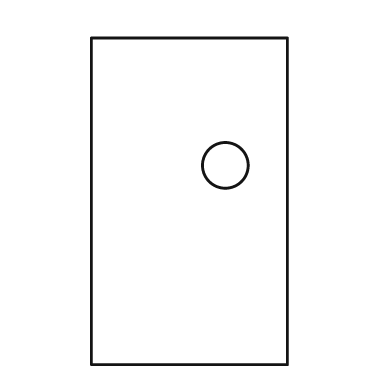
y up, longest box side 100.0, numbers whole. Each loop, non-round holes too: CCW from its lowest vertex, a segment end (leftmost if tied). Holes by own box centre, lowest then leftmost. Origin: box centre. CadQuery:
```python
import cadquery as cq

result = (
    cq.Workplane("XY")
    .moveTo(-30.0, -50.0)
    .lineTo(30.0, -50.0)
    .lineTo(30.0, 50.0)
    .lineTo(-30.0, 50.0)
    .close()
    .moveTo(11.0, 11.0)
    .circle(7.0)
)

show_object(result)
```